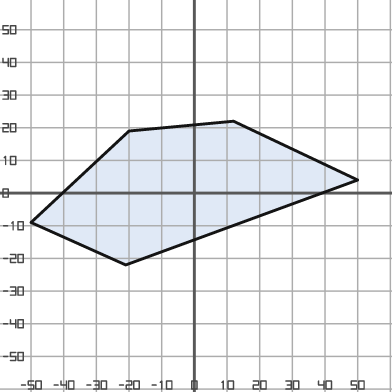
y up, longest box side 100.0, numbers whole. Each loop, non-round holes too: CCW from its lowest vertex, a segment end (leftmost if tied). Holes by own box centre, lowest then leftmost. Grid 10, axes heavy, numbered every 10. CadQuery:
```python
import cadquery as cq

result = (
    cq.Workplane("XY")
    .moveTo(-21.0, -22.0)
    .lineTo(50.0, 4.0)
    .lineTo(12.0, 22.0)
    .lineTo(-20.0, 19.0)
    .lineTo(-50.0, -9.0)
    .close()
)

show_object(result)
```